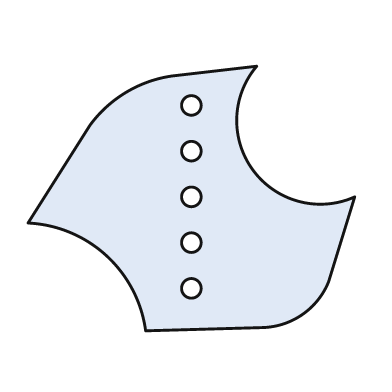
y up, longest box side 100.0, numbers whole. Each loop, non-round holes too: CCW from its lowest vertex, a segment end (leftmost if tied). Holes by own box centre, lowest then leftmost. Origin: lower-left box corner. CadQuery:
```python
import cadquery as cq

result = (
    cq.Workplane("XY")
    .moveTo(36.0, 0.0)
    .lineTo(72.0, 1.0)
    .threePointArc((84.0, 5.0), (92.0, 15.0))
    .lineTo(100.0, 41.0)
    .threePointArc((69.0, 49.0), (70.0, 81.0))
    .lineTo(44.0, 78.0)
    .threePointArc((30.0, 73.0), (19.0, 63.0))
    .lineTo(0.0, 33.0)
    .threePointArc((24.0, 23.0), (36.0, 0.0))
    .close()
    .moveTo(50.0, 13.0)
    .circle(3.0)
    .moveTo(50.0, 27.0)
    .circle(3.0)
    .moveTo(50.0, 41.0)
    .circle(3.0)
    .moveTo(50.0, 55.0)
    .circle(3.0)
    .moveTo(50.0, 69.0)
    .circle(3.0)
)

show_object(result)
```